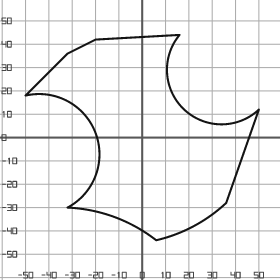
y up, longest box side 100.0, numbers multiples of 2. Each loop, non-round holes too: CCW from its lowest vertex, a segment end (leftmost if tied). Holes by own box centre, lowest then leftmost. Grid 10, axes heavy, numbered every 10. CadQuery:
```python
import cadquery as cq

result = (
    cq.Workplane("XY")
    .moveTo(6.0, -44.0)
    .threePointArc((22.0, -38.0), (36.0, -28.0))
    .lineTo(50.0, 12.0)
    .threePointArc((18.0, 12.0), (16.0, 44.0))
    .lineTo(-20.0, 42.0)
    .lineTo(-32.0, 36.0)
    .lineTo(-50.0, 18.0)
    .threePointArc((-20.0, 2.0), (-32.0, -30.0))
    .threePointArc((-12.0, -34.0), (6.0, -44.0))
    .close()
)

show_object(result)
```